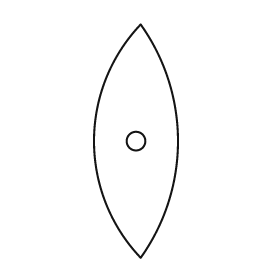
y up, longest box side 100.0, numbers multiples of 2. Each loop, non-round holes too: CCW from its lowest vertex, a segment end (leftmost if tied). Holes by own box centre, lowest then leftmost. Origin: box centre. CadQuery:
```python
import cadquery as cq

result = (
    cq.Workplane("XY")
    .moveTo(2.0, -50.0)
    .threePointArc((18.0, 0.0), (2.0, 50.0))
    .threePointArc((-18.0, 0.0), (2.0, -50.0))
    .close()
    .moveTo(0.0, 0.0)
    .circle(4.0)
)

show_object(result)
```